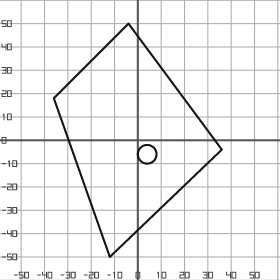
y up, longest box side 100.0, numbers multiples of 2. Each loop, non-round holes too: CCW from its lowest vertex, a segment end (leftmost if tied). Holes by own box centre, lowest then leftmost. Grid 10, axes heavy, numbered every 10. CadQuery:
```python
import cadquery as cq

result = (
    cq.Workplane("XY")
    .moveTo(-12.0, -50.0)
    .lineTo(36.0, -4.0)
    .lineTo(-4.0, 50.0)
    .lineTo(-36.0, 18.0)
    .close()
    .moveTo(4.0, -6.0)
    .circle(4.0)
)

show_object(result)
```